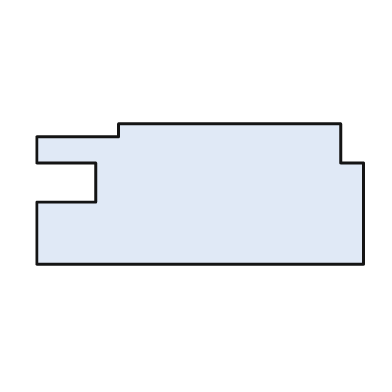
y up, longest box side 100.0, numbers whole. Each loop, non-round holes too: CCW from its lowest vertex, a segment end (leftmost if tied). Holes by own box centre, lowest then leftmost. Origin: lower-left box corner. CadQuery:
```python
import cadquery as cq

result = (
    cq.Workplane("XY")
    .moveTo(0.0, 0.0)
    .lineTo(100.0, 0.0)
    .lineTo(100.0, 31.0)
    .lineTo(93.0, 31.0)
    .lineTo(93.0, 43.0)
    .lineTo(25.0, 43.0)
    .lineTo(25.0, 39.0)
    .lineTo(0.0, 39.0)
    .lineTo(0.0, 31.0)
    .lineTo(18.0, 31.0)
    .lineTo(18.0, 19.0)
    .lineTo(0.0, 19.0)
    .close()
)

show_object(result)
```